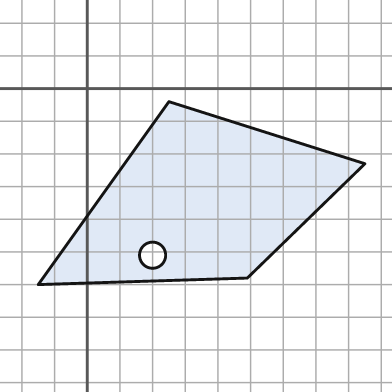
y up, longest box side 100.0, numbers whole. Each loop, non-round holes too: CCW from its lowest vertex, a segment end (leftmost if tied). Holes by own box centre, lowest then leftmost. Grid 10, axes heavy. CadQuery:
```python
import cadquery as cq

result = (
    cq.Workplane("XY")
    .moveTo(-15.0, -60.0)
    .lineTo(49.0, -58.0)
    .lineTo(85.0, -23.0)
    .lineTo(25.0, -4.0)
    .close()
    .moveTo(20.0, -51.0)
    .circle(4.0)
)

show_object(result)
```